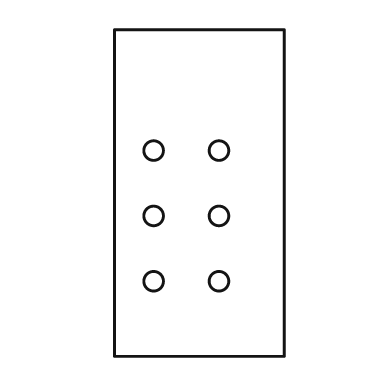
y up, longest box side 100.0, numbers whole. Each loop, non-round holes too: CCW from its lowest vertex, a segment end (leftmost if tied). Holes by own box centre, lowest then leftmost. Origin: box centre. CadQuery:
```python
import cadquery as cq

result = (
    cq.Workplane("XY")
    .moveTo(-26.0, -50.0)
    .lineTo(26.0, -50.0)
    .lineTo(26.0, 50.0)
    .lineTo(-26.0, 50.0)
    .close()
    .moveTo(-14.0, -27.0)
    .circle(3.0)
    .moveTo(6.0, -27.0)
    .circle(3.0)
    .moveTo(-14.0, -7.0)
    .circle(3.0)
    .moveTo(6.0, -7.0)
    .circle(3.0)
    .moveTo(-14.0, 13.0)
    .circle(3.0)
    .moveTo(6.0, 13.0)
    .circle(3.0)
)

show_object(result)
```